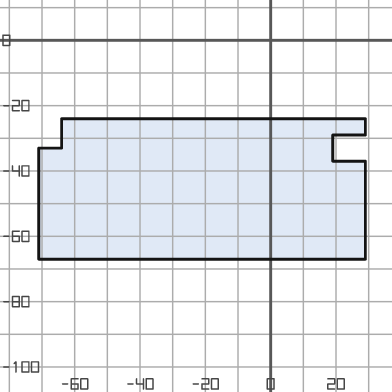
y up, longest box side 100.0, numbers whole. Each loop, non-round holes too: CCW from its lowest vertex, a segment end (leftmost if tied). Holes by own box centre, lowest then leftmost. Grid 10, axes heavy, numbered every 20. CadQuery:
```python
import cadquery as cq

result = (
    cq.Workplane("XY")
    .moveTo(-71.0, -67.0)
    .lineTo(29.0, -67.0)
    .lineTo(29.0, -37.0)
    .lineTo(19.0, -37.0)
    .lineTo(19.0, -29.0)
    .lineTo(29.0, -29.0)
    .lineTo(29.0, -24.0)
    .lineTo(-64.0, -24.0)
    .lineTo(-64.0, -33.0)
    .lineTo(-71.0, -33.0)
    .close()
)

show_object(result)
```